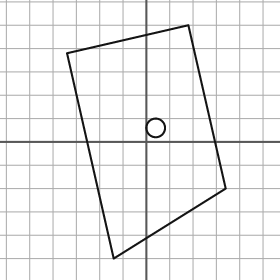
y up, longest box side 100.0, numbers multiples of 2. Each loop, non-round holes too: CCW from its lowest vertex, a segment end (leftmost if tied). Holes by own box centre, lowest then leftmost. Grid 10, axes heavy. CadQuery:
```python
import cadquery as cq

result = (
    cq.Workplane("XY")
    .moveTo(-14.0, -50.0)
    .lineTo(34.0, -20.0)
    .lineTo(18.0, 50.0)
    .lineTo(-34.0, 38.0)
    .close()
    .moveTo(4.0, 6.0)
    .circle(4.0)
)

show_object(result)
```